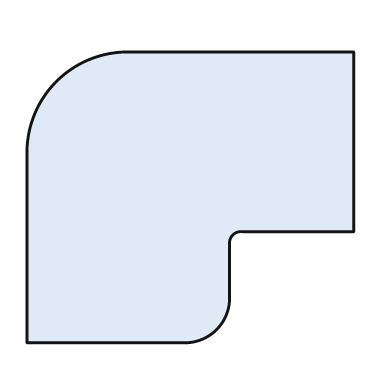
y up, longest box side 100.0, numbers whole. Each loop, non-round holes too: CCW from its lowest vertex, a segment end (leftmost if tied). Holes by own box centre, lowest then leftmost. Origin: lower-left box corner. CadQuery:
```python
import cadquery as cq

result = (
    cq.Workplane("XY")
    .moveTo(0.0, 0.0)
    .lineTo(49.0, 0.0)
    .threePointArc((58.0, 4.0), (62.0, 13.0))
    .lineTo(62.0, 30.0)
    .threePointArc((63.0, 33.0), (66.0, 34.0))
    .lineTo(100.0, 34.0)
    .lineTo(100.0, 89.0)
    .lineTo(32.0, 89.0)
    .threePointArc((9.0, 80.0), (0.0, 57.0))
    .close()
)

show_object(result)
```